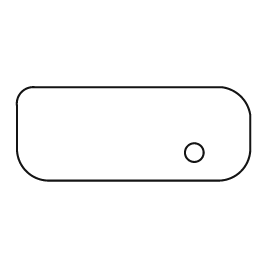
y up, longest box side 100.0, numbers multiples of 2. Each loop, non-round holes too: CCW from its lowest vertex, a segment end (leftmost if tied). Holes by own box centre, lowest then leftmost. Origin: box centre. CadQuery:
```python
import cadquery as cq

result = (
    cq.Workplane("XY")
    .moveTo(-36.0, -20.0)
    .lineTo(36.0, -20.0)
    .threePointArc((46.0, -16.0), (50.0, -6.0))
    .lineTo(50.0, 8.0)
    .threePointArc((46.0, 16.0), (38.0, 20.0))
    .lineTo(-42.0, 20.0)
    .threePointArc((-48.0, 18.0), (-50.0, 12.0))
    .lineTo(-50.0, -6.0)
    .threePointArc((-46.0, -16.0), (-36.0, -20.0))
    .close()
    .moveTo(26.0, -8.0)
    .circle(4.0)
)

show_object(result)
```